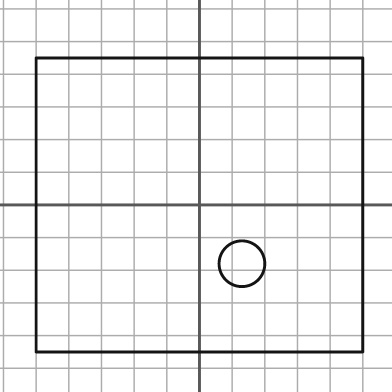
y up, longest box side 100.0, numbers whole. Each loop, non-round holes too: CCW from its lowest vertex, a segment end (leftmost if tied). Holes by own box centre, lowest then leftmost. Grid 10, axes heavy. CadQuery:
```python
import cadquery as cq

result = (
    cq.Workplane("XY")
    .moveTo(-50.0, -45.0)
    .lineTo(50.0, -45.0)
    .lineTo(50.0, 45.0)
    .lineTo(-50.0, 45.0)
    .close()
    .moveTo(13.0, -18.0)
    .circle(7.0)
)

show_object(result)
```